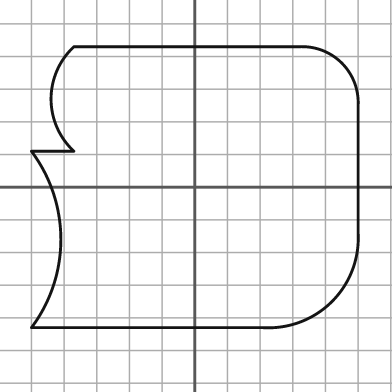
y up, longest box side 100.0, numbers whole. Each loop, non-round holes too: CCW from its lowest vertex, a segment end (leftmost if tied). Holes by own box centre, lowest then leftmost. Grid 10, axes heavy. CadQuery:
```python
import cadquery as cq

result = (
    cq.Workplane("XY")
    .moveTo(-50.0, -43.0)
    .lineTo(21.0, -43.0)
    .threePointArc((42.0, -35.0), (50.0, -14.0))
    .lineTo(50.0, 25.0)
    .threePointArc((45.0, 38.0), (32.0, 43.0))
    .lineTo(-37.0, 43.0)
    .threePointArc((-44.0, 27.0), (-37.0, 11.0))
    .lineTo(-50.0, 11.0)
    .threePointArc((-41.0, -16.0), (-50.0, -43.0))
    .close()
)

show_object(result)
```